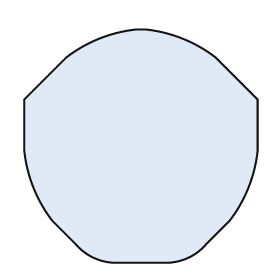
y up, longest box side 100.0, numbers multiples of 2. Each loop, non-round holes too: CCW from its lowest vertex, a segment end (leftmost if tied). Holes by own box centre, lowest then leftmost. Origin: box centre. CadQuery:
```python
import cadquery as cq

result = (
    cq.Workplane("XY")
    .moveTo(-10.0, -50.0)
    .lineTo(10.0, -50.0)
    .threePointArc((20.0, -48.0), (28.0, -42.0))
    .lineTo(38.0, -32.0)
    .threePointArc((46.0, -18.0), (50.0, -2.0))
    .lineTo(50.0, 20.0)
    .lineTo(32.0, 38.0)
    .threePointArc((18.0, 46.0), (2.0, 50.0))
    .lineTo(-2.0, 50.0)
    .threePointArc((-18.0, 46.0), (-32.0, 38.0))
    .lineTo(-50.0, 20.0)
    .lineTo(-50.0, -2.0)
    .threePointArc((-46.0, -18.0), (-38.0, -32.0))
    .lineTo(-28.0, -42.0)
    .threePointArc((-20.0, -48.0), (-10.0, -50.0))
    .close()
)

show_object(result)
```